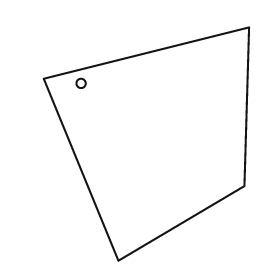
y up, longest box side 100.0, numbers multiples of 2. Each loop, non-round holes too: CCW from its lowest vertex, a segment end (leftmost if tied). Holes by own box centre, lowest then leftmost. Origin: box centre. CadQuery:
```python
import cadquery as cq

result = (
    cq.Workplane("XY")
    .moveTo(-12.0, -50.0)
    .lineTo(42.0, -18.0)
    .lineTo(44.0, 50.0)
    .lineTo(-44.0, 28.0)
    .close()
    .moveTo(-28.0, 26.0)
    .circle(2.0)
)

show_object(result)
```